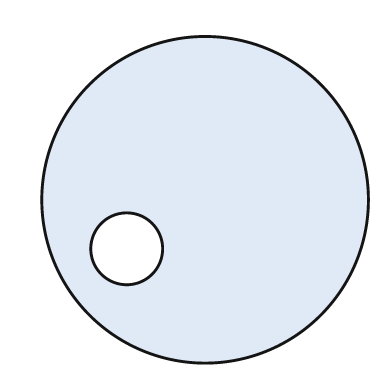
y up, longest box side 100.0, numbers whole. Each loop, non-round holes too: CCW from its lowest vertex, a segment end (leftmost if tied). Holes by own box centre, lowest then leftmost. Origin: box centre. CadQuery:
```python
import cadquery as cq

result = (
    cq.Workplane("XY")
    .moveTo(0.0, 0.0)
    .circle(50.0)
    .moveTo(-24.0, -15.0)
    .circle(11.0)
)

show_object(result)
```